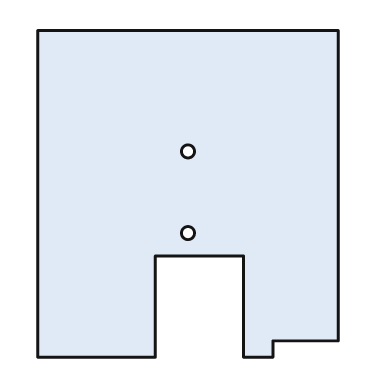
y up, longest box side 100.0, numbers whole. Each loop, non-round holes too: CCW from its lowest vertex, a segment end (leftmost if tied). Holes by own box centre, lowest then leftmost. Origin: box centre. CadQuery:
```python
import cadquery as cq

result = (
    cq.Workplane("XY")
    .moveTo(-46.0, -50.0)
    .lineTo(-10.0, -50.0)
    .lineTo(-10.0, -19.0)
    .lineTo(17.0, -19.0)
    .lineTo(17.0, -50.0)
    .lineTo(26.0, -50.0)
    .lineTo(26.0, -45.0)
    .lineTo(46.0, -45.0)
    .lineTo(46.0, 50.0)
    .lineTo(-46.0, 50.0)
    .close()
    .moveTo(0.0, -12.0)
    .circle(2.0)
    .moveTo(0.0, 13.0)
    .circle(2.0)
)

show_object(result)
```